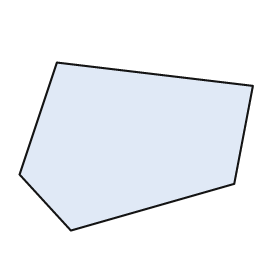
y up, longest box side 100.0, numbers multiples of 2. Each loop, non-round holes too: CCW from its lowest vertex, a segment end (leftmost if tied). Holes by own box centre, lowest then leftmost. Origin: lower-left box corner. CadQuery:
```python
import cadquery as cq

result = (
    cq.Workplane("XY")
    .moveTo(22.0, 0.0)
    .lineTo(92.0, 20.0)
    .lineTo(100.0, 62.0)
    .lineTo(16.0, 72.0)
    .lineTo(0.0, 24.0)
    .close()
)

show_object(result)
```